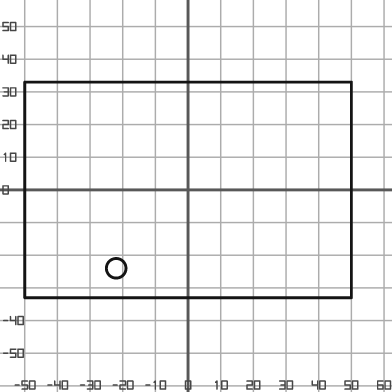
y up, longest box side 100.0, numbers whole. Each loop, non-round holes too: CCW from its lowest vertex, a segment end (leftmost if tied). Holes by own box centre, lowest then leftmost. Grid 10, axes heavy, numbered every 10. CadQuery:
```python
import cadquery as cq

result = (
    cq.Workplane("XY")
    .moveTo(-50.0, -33.0)
    .lineTo(50.0, -33.0)
    .lineTo(50.0, 33.0)
    .lineTo(-50.0, 33.0)
    .close()
    .moveTo(-22.0, -24.0)
    .circle(3.0)
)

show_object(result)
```